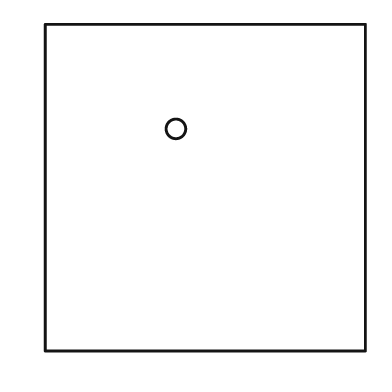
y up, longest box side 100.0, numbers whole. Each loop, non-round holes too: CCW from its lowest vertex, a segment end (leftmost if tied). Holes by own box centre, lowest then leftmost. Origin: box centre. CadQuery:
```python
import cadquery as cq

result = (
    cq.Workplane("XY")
    .moveTo(-49.0, -50.0)
    .lineTo(49.0, -50.0)
    .lineTo(49.0, 50.0)
    .lineTo(-49.0, 50.0)
    .close()
    .moveTo(-9.0, 18.0)
    .circle(3.0)
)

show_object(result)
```